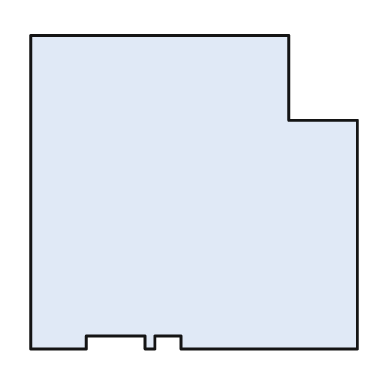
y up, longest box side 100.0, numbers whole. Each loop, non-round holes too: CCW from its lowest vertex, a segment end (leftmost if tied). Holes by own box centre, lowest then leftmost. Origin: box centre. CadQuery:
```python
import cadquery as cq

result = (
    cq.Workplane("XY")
    .moveTo(-50.0, -48.0)
    .lineTo(-33.0, -48.0)
    .lineTo(-33.0, -44.0)
    .lineTo(-15.0, -44.0)
    .lineTo(-15.0, -48.0)
    .lineTo(-12.0, -48.0)
    .lineTo(-12.0, -44.0)
    .lineTo(-4.0, -44.0)
    .lineTo(-4.0, -48.0)
    .lineTo(50.0, -48.0)
    .lineTo(50.0, 22.0)
    .lineTo(29.0, 22.0)
    .lineTo(29.0, 48.0)
    .lineTo(-50.0, 48.0)
    .close()
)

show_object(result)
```